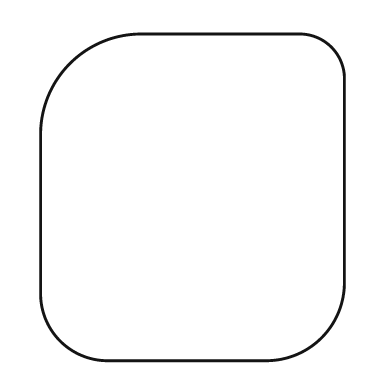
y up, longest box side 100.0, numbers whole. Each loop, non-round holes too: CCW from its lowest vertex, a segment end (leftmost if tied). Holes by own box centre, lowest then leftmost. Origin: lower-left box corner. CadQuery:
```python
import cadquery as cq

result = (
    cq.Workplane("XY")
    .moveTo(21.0, 0.0)
    .lineTo(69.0, 0.0)
    .threePointArc((86.0, 7.0), (93.0, 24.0))
    .lineTo(93.0, 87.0)
    .threePointArc((89.0, 96.0), (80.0, 100.0))
    .lineTo(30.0, 100.0)
    .threePointArc((9.0, 91.0), (0.0, 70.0))
    .lineTo(0.0, 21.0)
    .threePointArc((6.0, 6.0), (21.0, 0.0))
    .close()
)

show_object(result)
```